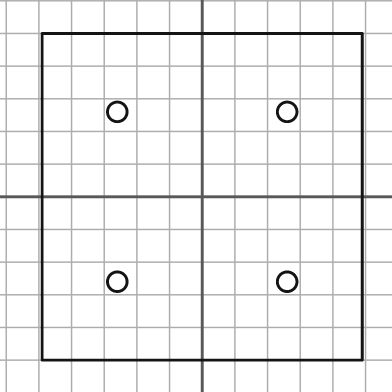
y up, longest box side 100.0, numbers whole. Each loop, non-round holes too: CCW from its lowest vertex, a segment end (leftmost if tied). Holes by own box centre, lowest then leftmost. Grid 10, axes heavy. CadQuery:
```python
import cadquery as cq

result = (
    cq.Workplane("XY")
    .moveTo(-49.0, -50.0)
    .lineTo(49.0, -50.0)
    .lineTo(49.0, 50.0)
    .lineTo(-49.0, 50.0)
    .close()
    .moveTo(-26.0, -26.0)
    .circle(3.0)
    .moveTo(26.0, -26.0)
    .circle(3.0)
    .moveTo(-26.0, 26.0)
    .circle(3.0)
    .moveTo(26.0, 26.0)
    .circle(3.0)
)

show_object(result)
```